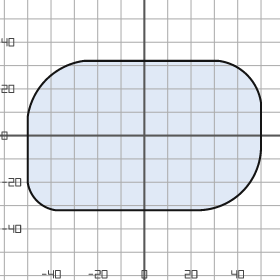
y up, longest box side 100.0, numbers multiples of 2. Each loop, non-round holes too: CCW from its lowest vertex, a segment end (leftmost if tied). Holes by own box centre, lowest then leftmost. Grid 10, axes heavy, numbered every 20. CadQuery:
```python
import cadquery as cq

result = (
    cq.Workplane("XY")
    .moveTo(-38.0, -32.0)
    .lineTo(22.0, -32.0)
    .threePointArc((42.0, -24.0), (50.0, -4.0))
    .lineTo(50.0, 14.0)
    .threePointArc((44.0, 26.0), (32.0, 32.0))
    .lineTo(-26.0, 32.0)
    .threePointArc((-42.0, 24.0), (-50.0, 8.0))
    .lineTo(-50.0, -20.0)
    .threePointArc((-46.0, -28.0), (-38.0, -32.0))
    .close()
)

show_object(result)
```